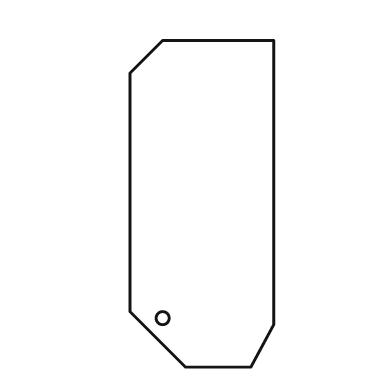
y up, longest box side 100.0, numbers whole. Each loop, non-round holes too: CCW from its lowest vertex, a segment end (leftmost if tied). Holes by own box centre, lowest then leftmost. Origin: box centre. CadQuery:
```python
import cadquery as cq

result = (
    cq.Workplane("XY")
    .moveTo(-5.0, -50.0)
    .lineTo(15.0, -50.0)
    .lineTo(22.0, -37.0)
    .lineTo(22.0, 50.0)
    .lineTo(-12.0, 50.0)
    .lineTo(-22.0, 40.0)
    .lineTo(-22.0, -33.0)
    .close()
    .moveTo(-12.0, -35.0)
    .circle(2.0)
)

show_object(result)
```